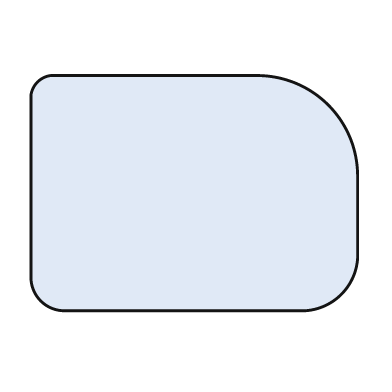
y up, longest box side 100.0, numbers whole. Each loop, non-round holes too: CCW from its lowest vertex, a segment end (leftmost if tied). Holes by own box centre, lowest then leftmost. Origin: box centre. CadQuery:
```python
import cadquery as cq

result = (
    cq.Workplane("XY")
    .moveTo(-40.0, -36.0)
    .lineTo(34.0, -36.0)
    .threePointArc((45.0, -31.0), (50.0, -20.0))
    .lineTo(50.0, 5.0)
    .threePointArc((41.0, 27.0), (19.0, 36.0))
    .lineTo(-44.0, 36.0)
    .threePointArc((-48.0, 34.0), (-50.0, 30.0))
    .lineTo(-50.0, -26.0)
    .threePointArc((-47.0, -33.0), (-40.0, -36.0))
    .close()
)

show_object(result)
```